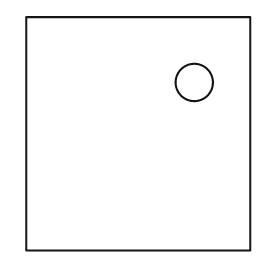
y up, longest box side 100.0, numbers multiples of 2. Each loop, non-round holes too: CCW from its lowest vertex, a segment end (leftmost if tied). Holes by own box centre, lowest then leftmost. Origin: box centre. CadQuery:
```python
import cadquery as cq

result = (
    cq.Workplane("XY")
    .moveTo(-48.0, -50.0)
    .lineTo(48.0, -50.0)
    .lineTo(48.0, 50.0)
    .lineTo(-48.0, 50.0)
    .close()
    .moveTo(24.0, 22.0)
    .circle(8.0)
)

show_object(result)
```